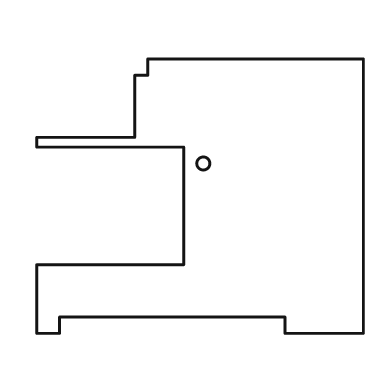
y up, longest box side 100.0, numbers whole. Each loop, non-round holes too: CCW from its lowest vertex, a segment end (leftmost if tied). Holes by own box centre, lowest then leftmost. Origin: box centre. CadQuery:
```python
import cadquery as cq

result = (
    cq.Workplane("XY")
    .moveTo(-50.0, -42.0)
    .lineTo(-43.0, -42.0)
    .lineTo(-43.0, -37.0)
    .lineTo(26.0, -37.0)
    .lineTo(26.0, -42.0)
    .lineTo(50.0, -42.0)
    .lineTo(50.0, 42.0)
    .lineTo(-16.0, 42.0)
    .lineTo(-16.0, 37.0)
    .lineTo(-20.0, 37.0)
    .lineTo(-20.0, 18.0)
    .lineTo(-50.0, 18.0)
    .lineTo(-50.0, 15.0)
    .lineTo(-5.0, 15.0)
    .lineTo(-5.0, -21.0)
    .lineTo(-50.0, -21.0)
    .close()
    .moveTo(1.0, 10.0)
    .circle(2.0)
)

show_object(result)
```